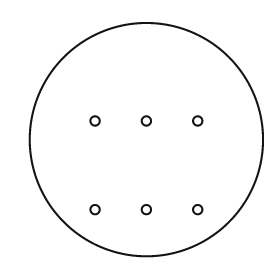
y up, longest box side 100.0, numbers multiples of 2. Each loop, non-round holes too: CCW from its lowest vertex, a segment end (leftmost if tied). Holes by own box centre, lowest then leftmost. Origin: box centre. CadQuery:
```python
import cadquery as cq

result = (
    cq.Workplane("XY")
    .moveTo(0.0, 0.0)
    .circle(50.0)
    .moveTo(-22.0, -30.0)
    .circle(2.0)
    .moveTo(0.0, -30.0)
    .circle(2.0)
    .moveTo(22.0, -30.0)
    .circle(2.0)
    .moveTo(-22.0, 8.0)
    .circle(2.0)
    .moveTo(0.0, 8.0)
    .circle(2.0)
    .moveTo(22.0, 8.0)
    .circle(2.0)
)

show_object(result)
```